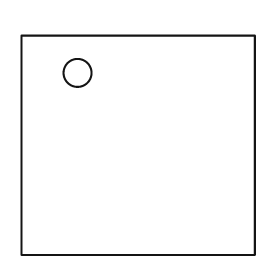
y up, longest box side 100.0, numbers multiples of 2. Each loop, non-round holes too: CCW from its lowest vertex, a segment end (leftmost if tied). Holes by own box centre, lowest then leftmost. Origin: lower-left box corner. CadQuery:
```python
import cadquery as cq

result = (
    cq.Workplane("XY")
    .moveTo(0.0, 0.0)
    .lineTo(100.0, 0.0)
    .lineTo(100.0, 94.0)
    .lineTo(0.0, 94.0)
    .close()
    .moveTo(24.0, 78.0)
    .circle(6.0)
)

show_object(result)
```